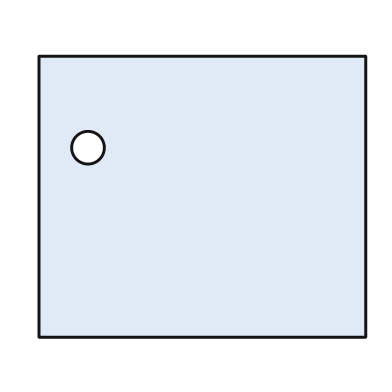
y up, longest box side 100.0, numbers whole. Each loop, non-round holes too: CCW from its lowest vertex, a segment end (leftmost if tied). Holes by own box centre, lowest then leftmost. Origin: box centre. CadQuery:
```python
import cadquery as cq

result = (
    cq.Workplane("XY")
    .moveTo(-50.0, -43.0)
    .lineTo(50.0, -43.0)
    .lineTo(50.0, 43.0)
    .lineTo(-50.0, 43.0)
    .close()
    .moveTo(-35.0, 15.0)
    .circle(5.0)
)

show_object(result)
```